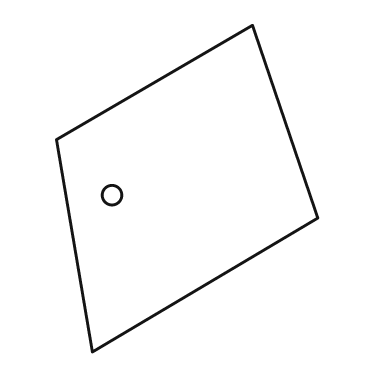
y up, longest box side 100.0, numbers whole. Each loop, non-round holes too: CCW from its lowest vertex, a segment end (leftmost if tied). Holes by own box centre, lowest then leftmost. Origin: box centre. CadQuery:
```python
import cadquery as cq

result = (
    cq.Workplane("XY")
    .moveTo(-29.0, -50.0)
    .lineTo(40.0, -9.0)
    .lineTo(20.0, 50.0)
    .lineTo(-40.0, 15.0)
    .close()
    .moveTo(-23.0, -2.0)
    .circle(3.0)
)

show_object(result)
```